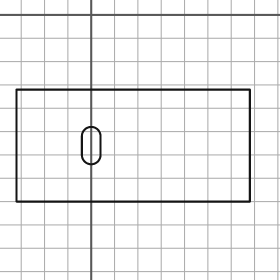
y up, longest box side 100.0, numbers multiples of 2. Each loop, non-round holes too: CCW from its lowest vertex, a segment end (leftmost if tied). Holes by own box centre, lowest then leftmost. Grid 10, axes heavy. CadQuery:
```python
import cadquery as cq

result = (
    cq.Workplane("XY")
    .moveTo(-32.0, -80.0)
    .lineTo(68.0, -80.0)
    .lineTo(68.0, -32.0)
    .lineTo(-32.0, -32.0)
    .close()
    .moveTo(-4.0, -60.0)
    .threePointArc((0.0, -64.0), (4.0, -60.0))
    .lineTo(4.0, -52.0)
    .threePointArc((0.0, -48.0), (-4.0, -52.0))
    .close()
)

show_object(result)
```